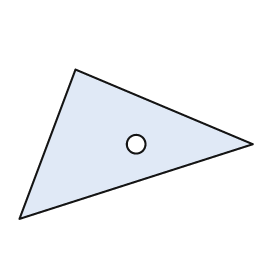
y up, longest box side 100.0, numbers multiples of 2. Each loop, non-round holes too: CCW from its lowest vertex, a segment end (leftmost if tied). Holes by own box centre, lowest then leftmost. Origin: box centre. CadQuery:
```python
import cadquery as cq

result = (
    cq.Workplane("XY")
    .moveTo(-50.0, -32.0)
    .lineTo(50.0, 0.0)
    .lineTo(-26.0, 32.0)
    .close()
    .moveTo(0.0, 0.0)
    .circle(4.0)
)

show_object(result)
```